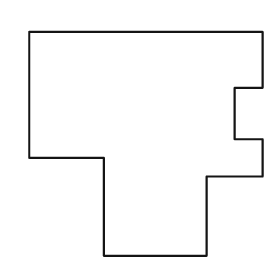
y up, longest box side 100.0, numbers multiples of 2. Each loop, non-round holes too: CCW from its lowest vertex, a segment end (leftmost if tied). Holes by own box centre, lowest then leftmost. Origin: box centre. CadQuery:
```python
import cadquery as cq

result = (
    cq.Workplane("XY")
    .moveTo(-18.0, -48.0)
    .lineTo(26.0, -48.0)
    .lineTo(26.0, -14.0)
    .lineTo(50.0, -14.0)
    .lineTo(50.0, 2.0)
    .lineTo(38.0, 2.0)
    .lineTo(38.0, 24.0)
    .lineTo(50.0, 24.0)
    .lineTo(50.0, 48.0)
    .lineTo(-50.0, 48.0)
    .lineTo(-50.0, -6.0)
    .lineTo(-18.0, -6.0)
    .close()
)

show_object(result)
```